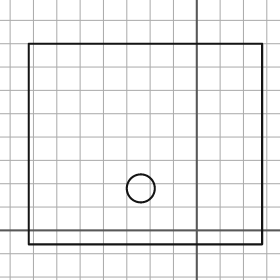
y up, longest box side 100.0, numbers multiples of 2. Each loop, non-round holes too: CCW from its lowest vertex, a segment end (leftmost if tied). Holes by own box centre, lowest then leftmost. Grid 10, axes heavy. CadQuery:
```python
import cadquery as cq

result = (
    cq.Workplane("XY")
    .moveTo(-72.0, -6.0)
    .lineTo(28.0, -6.0)
    .lineTo(28.0, 80.0)
    .lineTo(-72.0, 80.0)
    .close()
    .moveTo(-24.0, 18.0)
    .circle(6.0)
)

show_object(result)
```